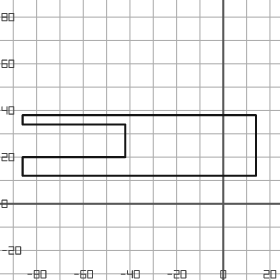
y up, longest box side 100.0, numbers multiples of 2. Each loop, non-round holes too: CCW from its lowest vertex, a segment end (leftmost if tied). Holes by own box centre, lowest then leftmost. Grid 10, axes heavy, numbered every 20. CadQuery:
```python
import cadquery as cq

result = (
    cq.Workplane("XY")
    .moveTo(-86.0, 12.0)
    .lineTo(14.0, 12.0)
    .lineTo(14.0, 38.0)
    .lineTo(-86.0, 38.0)
    .lineTo(-86.0, 34.0)
    .lineTo(-42.0, 34.0)
    .lineTo(-42.0, 20.0)
    .lineTo(-86.0, 20.0)
    .close()
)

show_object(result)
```